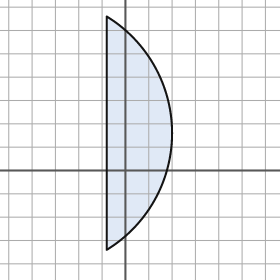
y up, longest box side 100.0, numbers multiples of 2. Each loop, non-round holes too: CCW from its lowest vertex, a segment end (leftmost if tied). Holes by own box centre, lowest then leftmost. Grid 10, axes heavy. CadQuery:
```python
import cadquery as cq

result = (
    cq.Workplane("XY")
    .moveTo(-8.0, -34.0)
    .threePointArc((20.0, 16.0), (-8.0, 66.0))
    .close()
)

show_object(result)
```